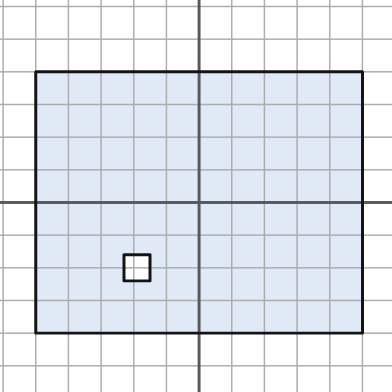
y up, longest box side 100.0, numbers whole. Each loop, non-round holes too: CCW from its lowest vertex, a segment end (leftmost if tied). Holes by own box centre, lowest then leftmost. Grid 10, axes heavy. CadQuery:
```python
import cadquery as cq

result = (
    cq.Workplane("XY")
    .moveTo(-50.0, -40.0)
    .lineTo(50.0, -40.0)
    .lineTo(50.0, 40.0)
    .lineTo(-50.0, 40.0)
    .close()
    .moveTo(-23.0, -24.0)
    .lineTo(-15.0, -24.0)
    .lineTo(-15.0, -16.0)
    .lineTo(-23.0, -16.0)
    .close()
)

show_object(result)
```